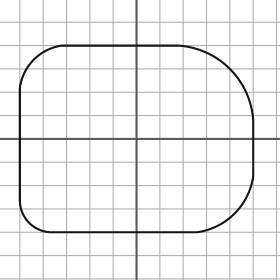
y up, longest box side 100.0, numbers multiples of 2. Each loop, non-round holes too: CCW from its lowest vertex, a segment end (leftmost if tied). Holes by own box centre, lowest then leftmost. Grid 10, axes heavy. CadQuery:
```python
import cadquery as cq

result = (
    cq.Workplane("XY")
    .moveTo(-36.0, -40.0)
    .lineTo(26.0, -40.0)
    .threePointArc((42.0, -32.0), (50.0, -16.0))
    .lineTo(50.0, 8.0)
    .threePointArc((40.0, 30.0), (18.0, 40.0))
    .lineTo(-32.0, 40.0)
    .threePointArc((-44.0, 34.0), (-50.0, 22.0))
    .lineTo(-50.0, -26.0)
    .threePointArc((-46.0, -36.0), (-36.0, -40.0))
    .close()
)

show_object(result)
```